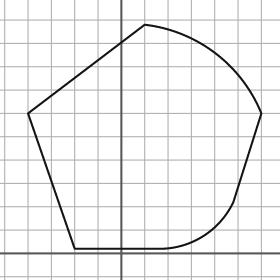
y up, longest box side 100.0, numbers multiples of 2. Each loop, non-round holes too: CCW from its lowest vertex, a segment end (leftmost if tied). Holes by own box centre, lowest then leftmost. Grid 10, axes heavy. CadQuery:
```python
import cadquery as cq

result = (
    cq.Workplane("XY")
    .moveTo(-20.0, 2.0)
    .lineTo(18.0, 2.0)
    .threePointArc((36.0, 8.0), (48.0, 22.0))
    .lineTo(60.0, 60.0)
    .threePointArc((40.0, 86.0), (10.0, 98.0))
    .lineTo(-40.0, 60.0)
    .close()
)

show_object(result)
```